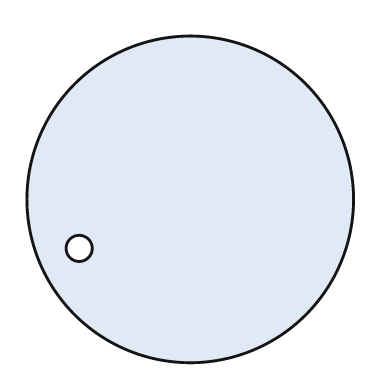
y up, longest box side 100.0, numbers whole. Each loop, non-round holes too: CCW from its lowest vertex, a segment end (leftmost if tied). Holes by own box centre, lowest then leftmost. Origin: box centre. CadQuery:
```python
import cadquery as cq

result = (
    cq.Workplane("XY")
    .moveTo(0.0, 0.0)
    .circle(50.0)
    .moveTo(-34.0, -15.0)
    .circle(4.0)
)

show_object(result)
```